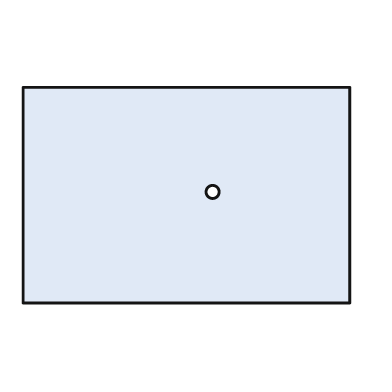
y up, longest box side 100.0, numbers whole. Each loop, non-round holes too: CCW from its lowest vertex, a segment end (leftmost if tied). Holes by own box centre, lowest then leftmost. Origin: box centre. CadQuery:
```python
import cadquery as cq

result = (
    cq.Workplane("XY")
    .moveTo(-50.0, -33.0)
    .lineTo(50.0, -33.0)
    .lineTo(50.0, 33.0)
    .lineTo(-50.0, 33.0)
    .close()
    .moveTo(8.0, 1.0)
    .circle(2.0)
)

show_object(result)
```